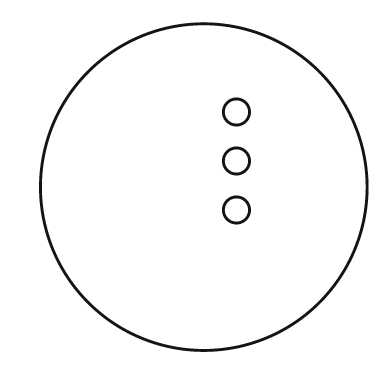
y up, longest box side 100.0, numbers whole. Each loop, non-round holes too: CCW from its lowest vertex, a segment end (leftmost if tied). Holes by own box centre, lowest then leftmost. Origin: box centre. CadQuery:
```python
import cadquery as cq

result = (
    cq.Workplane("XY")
    .moveTo(0.0, 0.0)
    .circle(50.0)
    .moveTo(10.0, -7.0)
    .circle(4.0)
    .moveTo(10.0, 8.0)
    .circle(4.0)
    .moveTo(10.0, 23.0)
    .circle(4.0)
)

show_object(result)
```